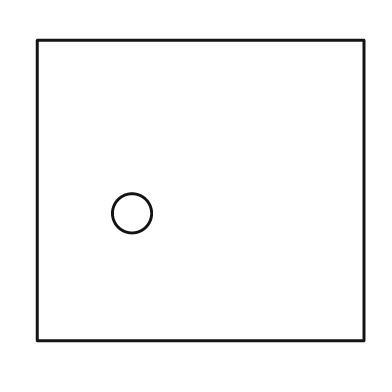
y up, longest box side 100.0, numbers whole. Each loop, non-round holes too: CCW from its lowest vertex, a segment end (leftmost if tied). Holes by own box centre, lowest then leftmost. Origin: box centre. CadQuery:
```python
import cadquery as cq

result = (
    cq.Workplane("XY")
    .moveTo(-50.0, -46.0)
    .lineTo(50.0, -46.0)
    .lineTo(50.0, 46.0)
    .lineTo(-50.0, 46.0)
    .close()
    .moveTo(-21.0, -7.0)
    .circle(6.0)
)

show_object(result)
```